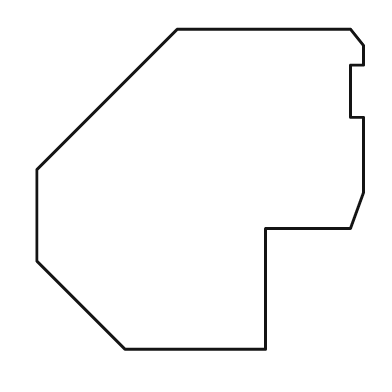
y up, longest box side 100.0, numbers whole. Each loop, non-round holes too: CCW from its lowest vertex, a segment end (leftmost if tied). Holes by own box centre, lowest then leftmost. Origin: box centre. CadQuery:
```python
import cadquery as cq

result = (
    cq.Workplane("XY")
    .moveTo(-23.0, -49.0)
    .lineTo(20.0, -49.0)
    .lineTo(20.0, -12.0)
    .lineTo(46.0, -12.0)
    .lineTo(50.0, -1.0)
    .lineTo(50.0, 22.0)
    .lineTo(46.0, 22.0)
    .lineTo(46.0, 38.0)
    .lineTo(50.0, 38.0)
    .lineTo(50.0, 44.0)
    .lineTo(46.0, 49.0)
    .lineTo(-7.0, 49.0)
    .lineTo(-50.0, 6.0)
    .lineTo(-50.0, -22.0)
    .close()
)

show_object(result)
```